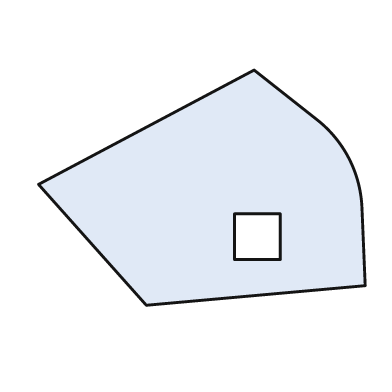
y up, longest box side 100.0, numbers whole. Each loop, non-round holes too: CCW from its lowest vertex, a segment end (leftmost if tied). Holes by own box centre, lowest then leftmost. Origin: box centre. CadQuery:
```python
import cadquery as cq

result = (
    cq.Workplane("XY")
    .moveTo(-17.0, -36.0)
    .lineTo(50.0, -30.0)
    .lineTo(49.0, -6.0)
    .threePointArc((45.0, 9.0), (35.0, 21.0))
    .lineTo(16.0, 36.0)
    .lineTo(-50.0, 1.0)
    .close()
    .moveTo(10.0, -22.0)
    .lineTo(24.0, -22.0)
    .lineTo(24.0, -8.0)
    .lineTo(10.0, -8.0)
    .close()
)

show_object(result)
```